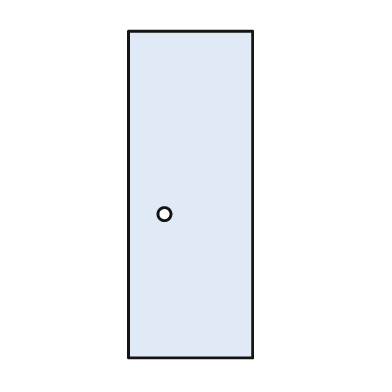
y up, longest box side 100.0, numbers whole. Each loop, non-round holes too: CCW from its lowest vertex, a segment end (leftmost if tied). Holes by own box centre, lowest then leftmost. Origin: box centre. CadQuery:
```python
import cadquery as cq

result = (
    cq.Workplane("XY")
    .moveTo(-19.0, -50.0)
    .lineTo(19.0, -50.0)
    .lineTo(19.0, 50.0)
    .lineTo(-19.0, 50.0)
    .close()
    .moveTo(-8.0, -6.0)
    .circle(2.0)
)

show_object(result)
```